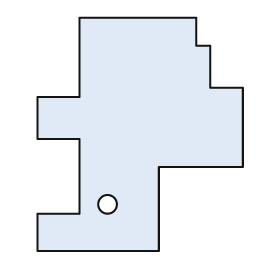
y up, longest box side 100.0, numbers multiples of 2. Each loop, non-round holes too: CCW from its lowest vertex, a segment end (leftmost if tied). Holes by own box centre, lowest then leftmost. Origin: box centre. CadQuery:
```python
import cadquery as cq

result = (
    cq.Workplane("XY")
    .moveTo(-44.0, -50.0)
    .lineTo(8.0, -50.0)
    .lineTo(8.0, -14.0)
    .lineTo(44.0, -14.0)
    .lineTo(44.0, 20.0)
    .lineTo(30.0, 20.0)
    .lineTo(30.0, 38.0)
    .lineTo(24.0, 38.0)
    .lineTo(24.0, 50.0)
    .lineTo(-26.0, 50.0)
    .lineTo(-26.0, 16.0)
    .lineTo(-44.0, 16.0)
    .lineTo(-44.0, -2.0)
    .lineTo(-26.0, -2.0)
    .lineTo(-26.0, -34.0)
    .lineTo(-44.0, -34.0)
    .close()
    .moveTo(-14.0, -30.0)
    .circle(4.0)
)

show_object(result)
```